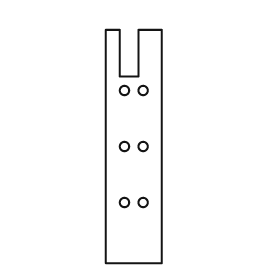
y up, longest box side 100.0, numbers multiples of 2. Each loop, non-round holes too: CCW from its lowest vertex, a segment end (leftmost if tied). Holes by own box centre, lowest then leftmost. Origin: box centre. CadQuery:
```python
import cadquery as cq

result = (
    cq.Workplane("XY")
    .moveTo(-12.0, -50.0)
    .lineTo(12.0, -50.0)
    .lineTo(12.0, 50.0)
    .lineTo(2.0, 50.0)
    .lineTo(2.0, 30.0)
    .lineTo(-6.0, 30.0)
    .lineTo(-6.0, 50.0)
    .lineTo(-12.0, 50.0)
    .close()
    .moveTo(-4.0, -24.0)
    .circle(2.0)
    .moveTo(4.0, -24.0)
    .circle(2.0)
    .moveTo(-4.0, 0.0)
    .circle(2.0)
    .moveTo(4.0, 0.0)
    .circle(2.0)
    .moveTo(-4.0, 24.0)
    .circle(2.0)
    .moveTo(4.0, 24.0)
    .circle(2.0)
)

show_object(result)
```